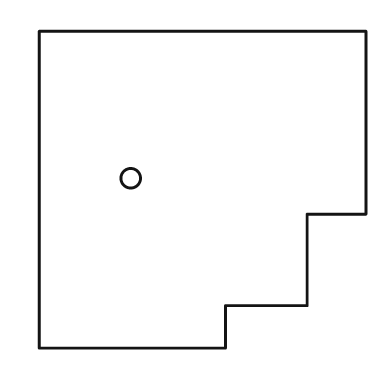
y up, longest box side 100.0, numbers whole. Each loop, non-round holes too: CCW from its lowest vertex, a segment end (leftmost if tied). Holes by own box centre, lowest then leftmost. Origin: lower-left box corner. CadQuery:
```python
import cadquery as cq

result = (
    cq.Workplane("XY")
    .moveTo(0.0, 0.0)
    .lineTo(57.0, 0.0)
    .lineTo(57.0, 13.0)
    .lineTo(82.0, 13.0)
    .lineTo(82.0, 41.0)
    .lineTo(100.0, 41.0)
    .lineTo(100.0, 97.0)
    .lineTo(0.0, 97.0)
    .close()
    .moveTo(28.0, 52.0)
    .circle(3.0)
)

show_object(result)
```